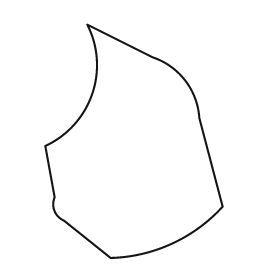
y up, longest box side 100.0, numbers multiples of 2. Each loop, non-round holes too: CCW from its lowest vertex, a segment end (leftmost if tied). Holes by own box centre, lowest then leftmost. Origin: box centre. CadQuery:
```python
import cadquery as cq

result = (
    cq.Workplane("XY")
    .moveTo(-10.0, -50.0)
    .threePointArc((16.0, -44.0), (38.0, -28.0))
    .lineTo(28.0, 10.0)
    .threePointArc((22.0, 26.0), (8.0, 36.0))
    .lineTo(-20.0, 50.0)
    .threePointArc((-18.0, 20.0), (-38.0, -2.0))
    .lineTo(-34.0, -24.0)
    .threePointArc((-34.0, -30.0), (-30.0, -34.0))
    .close()
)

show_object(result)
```